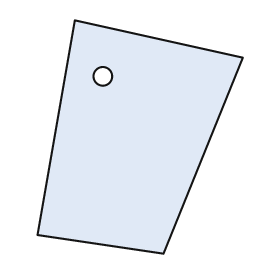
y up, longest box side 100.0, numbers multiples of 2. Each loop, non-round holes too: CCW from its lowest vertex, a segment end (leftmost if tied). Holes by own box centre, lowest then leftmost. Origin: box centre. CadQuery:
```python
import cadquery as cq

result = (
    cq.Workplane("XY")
    .moveTo(10.0, -50.0)
    .lineTo(44.0, 34.0)
    .lineTo(-28.0, 50.0)
    .lineTo(-44.0, -42.0)
    .close()
    .moveTo(-16.0, 26.0)
    .circle(4.0)
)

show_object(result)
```